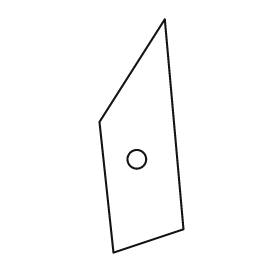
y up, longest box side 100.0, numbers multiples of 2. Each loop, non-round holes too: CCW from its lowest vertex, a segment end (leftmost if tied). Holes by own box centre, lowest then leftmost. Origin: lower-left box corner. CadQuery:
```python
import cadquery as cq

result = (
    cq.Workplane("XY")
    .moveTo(6.0, 0.0)
    .lineTo(36.0, 10.0)
    .lineTo(28.0, 100.0)
    .lineTo(0.0, 56.0)
    .close()
    .moveTo(16.0, 40.0)
    .circle(4.0)
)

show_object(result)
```